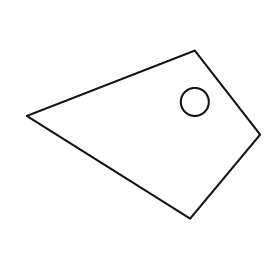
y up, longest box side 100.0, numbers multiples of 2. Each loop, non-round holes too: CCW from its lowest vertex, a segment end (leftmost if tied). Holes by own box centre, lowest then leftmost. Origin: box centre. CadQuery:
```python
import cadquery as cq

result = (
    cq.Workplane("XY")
    .moveTo(20.0, -36.0)
    .lineTo(50.0, 0.0)
    .lineTo(22.0, 36.0)
    .lineTo(-50.0, 8.0)
    .close()
    .moveTo(22.0, 14.0)
    .circle(6.0)
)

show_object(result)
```